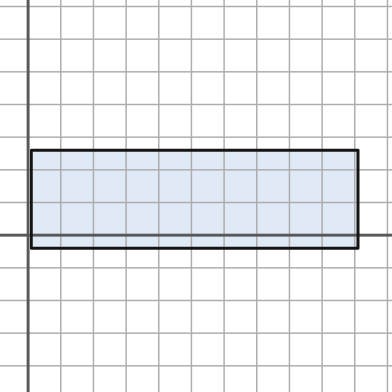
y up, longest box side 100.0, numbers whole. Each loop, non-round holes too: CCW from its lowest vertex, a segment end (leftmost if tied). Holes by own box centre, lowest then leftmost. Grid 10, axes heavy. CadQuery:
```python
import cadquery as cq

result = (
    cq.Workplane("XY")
    .moveTo(1.0, -4.0)
    .lineTo(101.0, -4.0)
    .lineTo(101.0, 26.0)
    .lineTo(1.0, 26.0)
    .close()
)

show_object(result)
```